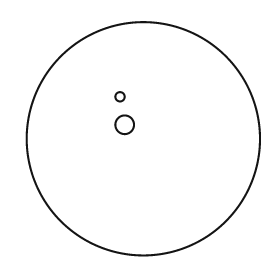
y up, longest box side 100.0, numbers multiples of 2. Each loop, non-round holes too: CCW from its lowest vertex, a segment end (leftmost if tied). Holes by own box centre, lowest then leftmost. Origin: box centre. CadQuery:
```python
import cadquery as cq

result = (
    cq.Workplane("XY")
    .moveTo(0.0, 0.0)
    .circle(50.0)
    .moveTo(-8.0, 6.0)
    .circle(4.0)
    .moveTo(-10.0, 18.0)
    .circle(2.0)
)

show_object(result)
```